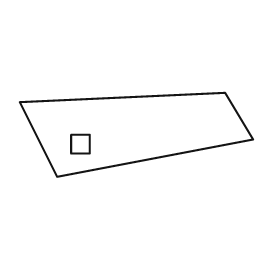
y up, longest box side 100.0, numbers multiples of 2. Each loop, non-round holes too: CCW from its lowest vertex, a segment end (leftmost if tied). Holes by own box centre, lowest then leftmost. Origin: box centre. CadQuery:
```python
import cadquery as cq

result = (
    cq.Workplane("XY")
    .moveTo(-34.0, -18.0)
    .lineTo(50.0, -2.0)
    .lineTo(38.0, 18.0)
    .lineTo(-50.0, 14.0)
    .close()
    .moveTo(-28.0, -8.0)
    .lineTo(-20.0, -8.0)
    .lineTo(-20.0, 0.0)
    .lineTo(-28.0, 0.0)
    .close()
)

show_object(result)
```